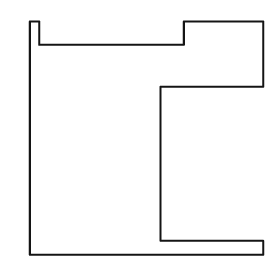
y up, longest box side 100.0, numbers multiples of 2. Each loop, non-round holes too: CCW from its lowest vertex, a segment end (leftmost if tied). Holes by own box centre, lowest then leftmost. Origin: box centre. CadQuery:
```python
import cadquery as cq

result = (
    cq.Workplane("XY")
    .moveTo(-50.0, -50.0)
    .lineTo(50.0, -50.0)
    .lineTo(50.0, -44.0)
    .lineTo(6.0, -44.0)
    .lineTo(6.0, 22.0)
    .lineTo(50.0, 22.0)
    .lineTo(50.0, 50.0)
    .lineTo(16.0, 50.0)
    .lineTo(16.0, 40.0)
    .lineTo(-46.0, 40.0)
    .lineTo(-46.0, 50.0)
    .lineTo(-50.0, 50.0)
    .close()
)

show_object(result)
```